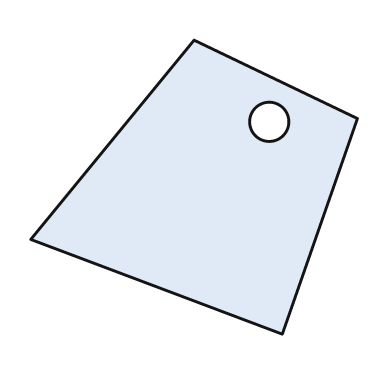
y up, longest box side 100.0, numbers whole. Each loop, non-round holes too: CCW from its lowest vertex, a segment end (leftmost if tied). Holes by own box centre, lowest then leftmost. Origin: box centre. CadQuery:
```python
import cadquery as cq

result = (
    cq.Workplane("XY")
    .moveTo(27.0, -45.0)
    .lineTo(50.0, 21.0)
    .lineTo(0.0, 45.0)
    .lineTo(-50.0, -16.0)
    .close()
    .moveTo(23.0, 20.0)
    .circle(6.0)
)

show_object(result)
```